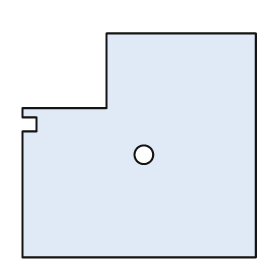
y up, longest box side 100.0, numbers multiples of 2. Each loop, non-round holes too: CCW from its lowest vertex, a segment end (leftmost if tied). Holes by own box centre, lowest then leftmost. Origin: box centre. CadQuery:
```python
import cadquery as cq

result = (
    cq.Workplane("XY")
    .moveTo(-50.0, -48.0)
    .lineTo(50.0, -48.0)
    .lineTo(50.0, 48.0)
    .lineTo(-14.0, 48.0)
    .lineTo(-14.0, 16.0)
    .lineTo(-50.0, 16.0)
    .lineTo(-50.0, 12.0)
    .lineTo(-44.0, 12.0)
    .lineTo(-44.0, 6.0)
    .lineTo(-50.0, 6.0)
    .close()
    .moveTo(2.0, -4.0)
    .circle(4.0)
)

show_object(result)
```